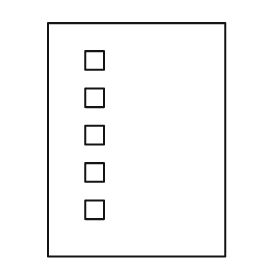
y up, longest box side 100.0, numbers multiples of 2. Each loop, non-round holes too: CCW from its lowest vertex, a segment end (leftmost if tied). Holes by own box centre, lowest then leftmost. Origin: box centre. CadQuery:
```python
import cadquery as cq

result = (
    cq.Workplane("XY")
    .moveTo(-38.0, -50.0)
    .lineTo(38.0, -50.0)
    .lineTo(38.0, 50.0)
    .lineTo(-38.0, 50.0)
    .close()
    .moveTo(-22.0, -34.0)
    .lineTo(-14.0, -34.0)
    .lineTo(-14.0, -26.0)
    .lineTo(-22.0, -26.0)
    .close()
    .moveTo(-22.0, -18.0)
    .lineTo(-14.0, -18.0)
    .lineTo(-14.0, -10.0)
    .lineTo(-22.0, -10.0)
    .close()
    .moveTo(-22.0, -2.0)
    .lineTo(-14.0, -2.0)
    .lineTo(-14.0, 6.0)
    .lineTo(-22.0, 6.0)
    .close()
    .moveTo(-22.0, 14.0)
    .lineTo(-14.0, 14.0)
    .lineTo(-14.0, 22.0)
    .lineTo(-22.0, 22.0)
    .close()
    .moveTo(-22.0, 30.0)
    .lineTo(-14.0, 30.0)
    .lineTo(-14.0, 38.0)
    .lineTo(-22.0, 38.0)
    .close()
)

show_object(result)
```